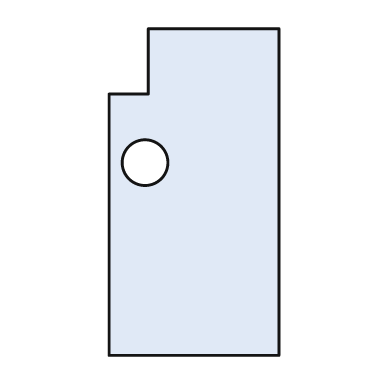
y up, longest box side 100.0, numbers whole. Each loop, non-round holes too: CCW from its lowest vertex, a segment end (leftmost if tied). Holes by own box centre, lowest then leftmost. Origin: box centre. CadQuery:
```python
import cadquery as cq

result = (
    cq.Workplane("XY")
    .moveTo(-26.0, -50.0)
    .lineTo(26.0, -50.0)
    .lineTo(26.0, 50.0)
    .lineTo(-14.0, 50.0)
    .lineTo(-14.0, 30.0)
    .lineTo(-26.0, 30.0)
    .close()
    .moveTo(-15.0, 9.0)
    .circle(7.0)
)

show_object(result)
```